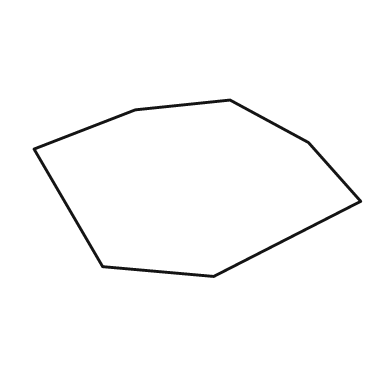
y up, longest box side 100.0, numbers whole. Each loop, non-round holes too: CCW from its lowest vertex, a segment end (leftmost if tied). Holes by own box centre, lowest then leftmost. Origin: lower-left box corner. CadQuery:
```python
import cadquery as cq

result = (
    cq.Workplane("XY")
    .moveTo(55.0, 0.0)
    .lineTo(100.0, 23.0)
    .lineTo(84.0, 41.0)
    .lineTo(60.0, 54.0)
    .lineTo(31.0, 51.0)
    .lineTo(0.0, 39.0)
    .lineTo(21.0, 3.0)
    .close()
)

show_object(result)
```